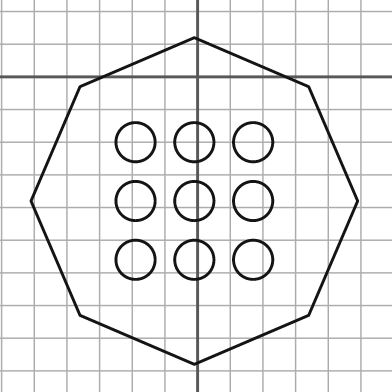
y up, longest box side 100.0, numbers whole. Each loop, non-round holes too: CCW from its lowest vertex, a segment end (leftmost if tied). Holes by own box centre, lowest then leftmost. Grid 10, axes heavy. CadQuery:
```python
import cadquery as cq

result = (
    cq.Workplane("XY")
    .moveTo(-1.0, -88.0)
    .lineTo(34.0, -73.0)
    .lineTo(49.0, -38.0)
    .lineTo(34.0, -3.0)
    .lineTo(-1.0, 12.0)
    .lineTo(-36.0, -3.0)
    .lineTo(-51.0, -38.0)
    .lineTo(-36.0, -73.0)
    .close()
    .moveTo(-19.0, -56.0)
    .circle(6.0)
    .moveTo(-1.0, -56.0)
    .circle(6.0)
    .moveTo(17.0, -56.0)
    .circle(6.0)
    .moveTo(-19.0, -38.0)
    .circle(6.0)
    .moveTo(-1.0, -38.0)
    .circle(6.0)
    .moveTo(17.0, -38.0)
    .circle(6.0)
    .moveTo(-19.0, -20.0)
    .circle(6.0)
    .moveTo(-1.0, -20.0)
    .circle(6.0)
    .moveTo(17.0, -20.0)
    .circle(6.0)
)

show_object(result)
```